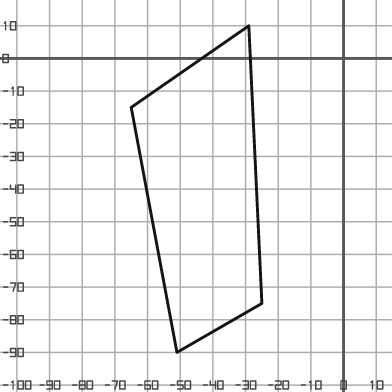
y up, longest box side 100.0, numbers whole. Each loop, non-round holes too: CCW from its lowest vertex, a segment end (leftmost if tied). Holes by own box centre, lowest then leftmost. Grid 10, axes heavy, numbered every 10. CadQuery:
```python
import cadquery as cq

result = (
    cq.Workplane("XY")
    .moveTo(-51.0, -90.0)
    .lineTo(-25.0, -75.0)
    .lineTo(-29.0, 10.0)
    .lineTo(-65.0, -15.0)
    .close()
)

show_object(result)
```